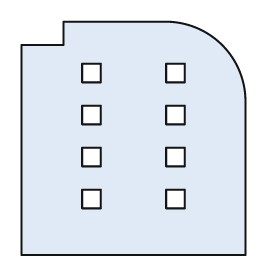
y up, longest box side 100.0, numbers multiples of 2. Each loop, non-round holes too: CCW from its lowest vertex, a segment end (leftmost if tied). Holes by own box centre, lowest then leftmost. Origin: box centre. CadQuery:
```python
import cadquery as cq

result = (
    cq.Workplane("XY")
    .moveTo(-48.0, -50.0)
    .lineTo(48.0, -50.0)
    .lineTo(48.0, 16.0)
    .threePointArc((38.0, 40.0), (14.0, 50.0))
    .lineTo(-30.0, 50.0)
    .lineTo(-30.0, 40.0)
    .lineTo(-48.0, 40.0)
    .close()
    .moveTo(-22.0, -30.0)
    .lineTo(-14.0, -30.0)
    .lineTo(-14.0, -22.0)
    .lineTo(-22.0, -22.0)
    .close()
    .moveTo(14.0, -30.0)
    .lineTo(22.0, -30.0)
    .lineTo(22.0, -22.0)
    .lineTo(14.0, -22.0)
    .close()
    .moveTo(-22.0, -12.0)
    .lineTo(-14.0, -12.0)
    .lineTo(-14.0, -4.0)
    .lineTo(-22.0, -4.0)
    .close()
    .moveTo(14.0, -12.0)
    .lineTo(22.0, -12.0)
    .lineTo(22.0, -4.0)
    .lineTo(14.0, -4.0)
    .close()
    .moveTo(-22.0, 6.0)
    .lineTo(-14.0, 6.0)
    .lineTo(-14.0, 14.0)
    .lineTo(-22.0, 14.0)
    .close()
    .moveTo(14.0, 6.0)
    .lineTo(22.0, 6.0)
    .lineTo(22.0, 14.0)
    .lineTo(14.0, 14.0)
    .close()
    .moveTo(-22.0, 24.0)
    .lineTo(-14.0, 24.0)
    .lineTo(-14.0, 32.0)
    .lineTo(-22.0, 32.0)
    .close()
    .moveTo(14.0, 24.0)
    .lineTo(22.0, 24.0)
    .lineTo(22.0, 32.0)
    .lineTo(14.0, 32.0)
    .close()
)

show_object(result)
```